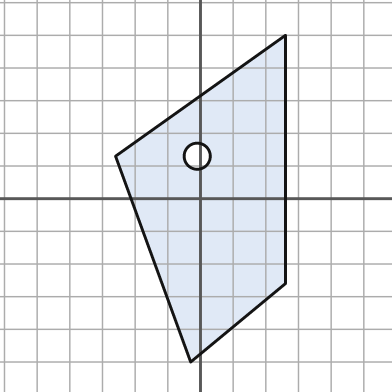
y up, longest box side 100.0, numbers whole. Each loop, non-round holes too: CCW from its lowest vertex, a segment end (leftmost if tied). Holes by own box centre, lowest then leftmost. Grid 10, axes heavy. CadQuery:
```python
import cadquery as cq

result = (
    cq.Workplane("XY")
    .moveTo(-3.0, -50.0)
    .lineTo(26.0, -26.0)
    .lineTo(26.0, 50.0)
    .lineTo(-26.0, 13.0)
    .close()
    .moveTo(-1.0, 13.0)
    .circle(4.0)
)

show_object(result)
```